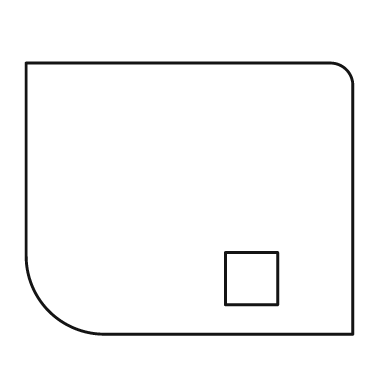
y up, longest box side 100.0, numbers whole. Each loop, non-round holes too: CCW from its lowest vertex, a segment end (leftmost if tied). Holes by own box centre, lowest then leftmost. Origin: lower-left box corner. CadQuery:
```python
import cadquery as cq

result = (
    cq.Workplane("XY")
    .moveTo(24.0, 0.0)
    .lineTo(100.0, 0.0)
    .lineTo(100.0, 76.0)
    .threePointArc((98.0, 81.0), (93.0, 83.0))
    .lineTo(0.0, 83.0)
    .lineTo(0.0, 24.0)
    .threePointArc((7.0, 7.0), (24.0, 0.0))
    .close()
    .moveTo(61.0, 9.0)
    .lineTo(77.0, 9.0)
    .lineTo(77.0, 25.0)
    .lineTo(61.0, 25.0)
    .close()
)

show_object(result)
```